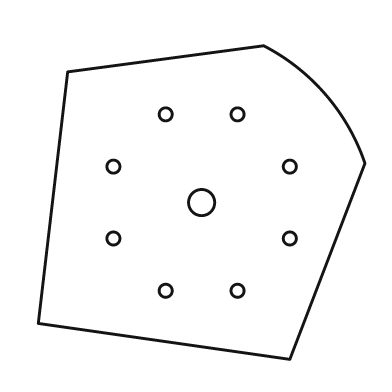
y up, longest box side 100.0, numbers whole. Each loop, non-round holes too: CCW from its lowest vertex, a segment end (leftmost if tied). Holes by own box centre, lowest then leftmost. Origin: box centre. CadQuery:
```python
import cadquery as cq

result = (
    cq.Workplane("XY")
    .moveTo(27.0, -48.0)
    .lineTo(50.0, 12.0)
    .threePointArc((38.0, 33.0), (19.0, 48.0))
    .lineTo(-41.0, 40.0)
    .lineTo(-50.0, -37.0)
    .close()
    .moveTo(-11.0, -27.0)
    .circle(2.0)
    .moveTo(11.0, -27.0)
    .circle(2.0)
    .moveTo(-27.0, -11.0)
    .circle(2.0)
    .moveTo(27.0, -11.0)
    .circle(2.0)
    .moveTo(0.0, 0.0)
    .circle(4.0)
    .moveTo(-27.0, 11.0)
    .circle(2.0)
    .moveTo(27.0, 11.0)
    .circle(2.0)
    .moveTo(-11.0, 27.0)
    .circle(2.0)
    .moveTo(11.0, 27.0)
    .circle(2.0)
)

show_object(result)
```